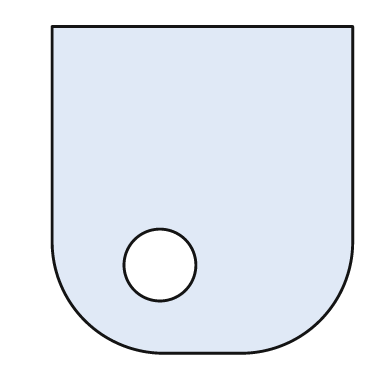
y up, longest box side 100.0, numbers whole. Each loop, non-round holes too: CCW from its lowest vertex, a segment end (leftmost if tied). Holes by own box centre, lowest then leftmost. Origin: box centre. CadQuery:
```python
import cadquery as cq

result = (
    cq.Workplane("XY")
    .moveTo(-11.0, -50.0)
    .lineTo(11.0, -50.0)
    .threePointArc((36.0, -40.0), (46.0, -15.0))
    .lineTo(46.0, 50.0)
    .lineTo(-46.0, 50.0)
    .lineTo(-46.0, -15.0)
    .threePointArc((-36.0, -40.0), (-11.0, -50.0))
    .close()
    .moveTo(-13.0, -23.0)
    .circle(11.0)
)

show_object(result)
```